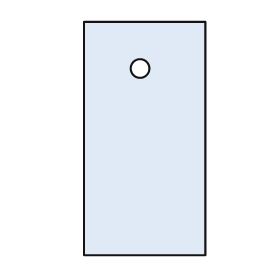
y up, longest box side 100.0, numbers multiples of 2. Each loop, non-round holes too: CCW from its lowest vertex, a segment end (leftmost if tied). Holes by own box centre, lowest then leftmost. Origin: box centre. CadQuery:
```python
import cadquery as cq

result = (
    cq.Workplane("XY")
    .moveTo(-26.0, -50.0)
    .lineTo(26.0, -50.0)
    .lineTo(26.0, 50.0)
    .lineTo(-26.0, 50.0)
    .close()
    .moveTo(-2.0, 30.0)
    .circle(4.0)
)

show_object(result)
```